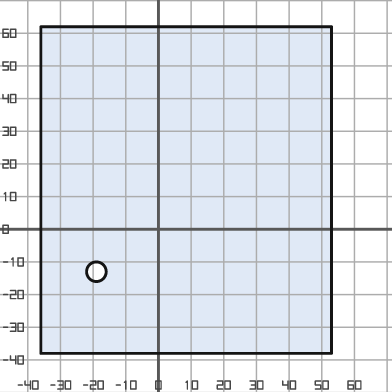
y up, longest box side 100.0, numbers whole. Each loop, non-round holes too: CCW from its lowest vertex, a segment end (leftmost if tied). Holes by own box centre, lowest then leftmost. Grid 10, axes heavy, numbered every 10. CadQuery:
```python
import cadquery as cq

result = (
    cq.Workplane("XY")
    .moveTo(-36.0, -38.0)
    .lineTo(53.0, -38.0)
    .lineTo(53.0, 62.0)
    .lineTo(-36.0, 62.0)
    .close()
    .moveTo(-19.0, -13.0)
    .circle(3.0)
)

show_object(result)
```